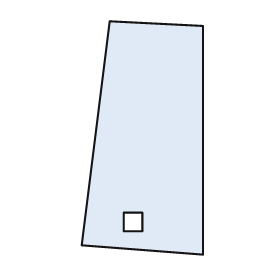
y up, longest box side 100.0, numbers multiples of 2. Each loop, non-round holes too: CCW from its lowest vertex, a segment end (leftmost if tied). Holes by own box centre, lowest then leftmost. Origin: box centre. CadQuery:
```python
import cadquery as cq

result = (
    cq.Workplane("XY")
    .moveTo(26.0, -50.0)
    .lineTo(26.0, 48.0)
    .lineTo(-14.0, 50.0)
    .lineTo(-26.0, -46.0)
    .close()
    .moveTo(-8.0, -40.0)
    .lineTo(0.0, -40.0)
    .lineTo(0.0, -32.0)
    .lineTo(-8.0, -32.0)
    .close()
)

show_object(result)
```